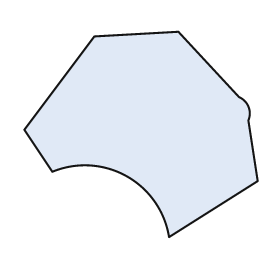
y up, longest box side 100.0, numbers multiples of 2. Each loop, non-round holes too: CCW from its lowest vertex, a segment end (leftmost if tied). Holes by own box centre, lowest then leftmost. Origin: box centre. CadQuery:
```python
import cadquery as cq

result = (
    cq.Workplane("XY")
    .moveTo(12.0, -44.0)
    .lineTo(50.0, -20.0)
    .lineTo(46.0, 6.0)
    .threePointArc((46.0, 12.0), (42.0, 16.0))
    .lineTo(16.0, 44.0)
    .lineTo(-20.0, 42.0)
    .lineTo(-50.0, 2.0)
    .lineTo(-38.0, -16.0)
    .threePointArc((-6.0, -18.0), (12.0, -44.0))
    .close()
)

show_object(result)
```